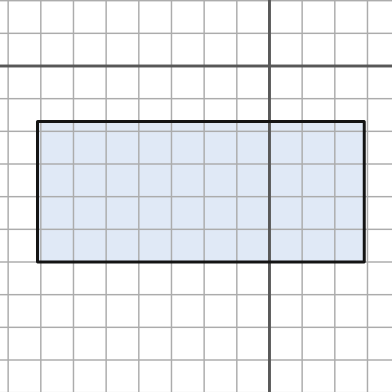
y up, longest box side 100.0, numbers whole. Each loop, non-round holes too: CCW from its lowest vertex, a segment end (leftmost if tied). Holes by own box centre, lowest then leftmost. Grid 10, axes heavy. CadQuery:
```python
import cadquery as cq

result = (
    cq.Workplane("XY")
    .moveTo(-71.0, -60.0)
    .lineTo(29.0, -60.0)
    .lineTo(29.0, -17.0)
    .lineTo(-71.0, -17.0)
    .close()
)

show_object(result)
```